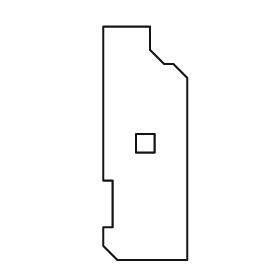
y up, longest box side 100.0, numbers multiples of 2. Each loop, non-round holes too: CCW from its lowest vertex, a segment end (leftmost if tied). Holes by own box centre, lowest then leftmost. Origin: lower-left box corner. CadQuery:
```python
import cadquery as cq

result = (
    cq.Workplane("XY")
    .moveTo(6.0, 0.0)
    .lineTo(36.0, 0.0)
    .lineTo(36.0, 78.0)
    .lineTo(30.0, 84.0)
    .lineTo(26.0, 84.0)
    .lineTo(20.0, 90.0)
    .lineTo(20.0, 100.0)
    .lineTo(0.0, 100.0)
    .lineTo(0.0, 34.0)
    .lineTo(4.0, 34.0)
    .lineTo(4.0, 14.0)
    .lineTo(0.0, 14.0)
    .lineTo(0.0, 6.0)
    .close()
    .moveTo(14.0, 46.0)
    .lineTo(22.0, 46.0)
    .lineTo(22.0, 54.0)
    .lineTo(14.0, 54.0)
    .close()
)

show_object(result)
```